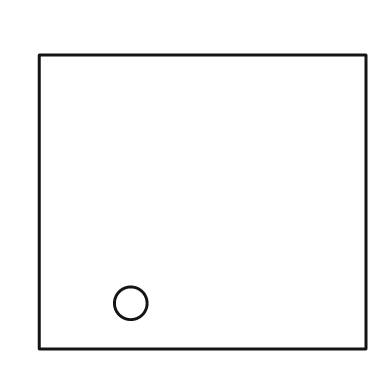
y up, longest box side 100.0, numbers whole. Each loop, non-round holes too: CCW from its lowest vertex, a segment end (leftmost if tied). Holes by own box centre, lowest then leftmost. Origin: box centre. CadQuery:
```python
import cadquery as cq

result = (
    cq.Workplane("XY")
    .moveTo(-50.0, -45.0)
    .lineTo(50.0, -45.0)
    .lineTo(50.0, 45.0)
    .lineTo(-50.0, 45.0)
    .close()
    .moveTo(-22.0, -31.0)
    .circle(5.0)
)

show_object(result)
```